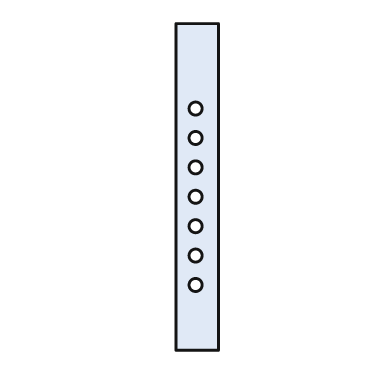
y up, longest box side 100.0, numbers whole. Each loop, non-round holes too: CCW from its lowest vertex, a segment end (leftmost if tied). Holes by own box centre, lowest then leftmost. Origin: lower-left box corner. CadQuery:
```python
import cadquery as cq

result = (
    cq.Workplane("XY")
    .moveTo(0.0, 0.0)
    .lineTo(13.0, 0.0)
    .lineTo(13.0, 100.0)
    .lineTo(0.0, 100.0)
    .close()
    .moveTo(6.0, 20.0)
    .circle(2.0)
    .moveTo(6.0, 29.0)
    .circle(2.0)
    .moveTo(6.0, 38.0)
    .circle(2.0)
    .moveTo(6.0, 47.0)
    .circle(2.0)
    .moveTo(6.0, 56.0)
    .circle(2.0)
    .moveTo(6.0, 65.0)
    .circle(2.0)
    .moveTo(6.0, 74.0)
    .circle(2.0)
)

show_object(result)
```